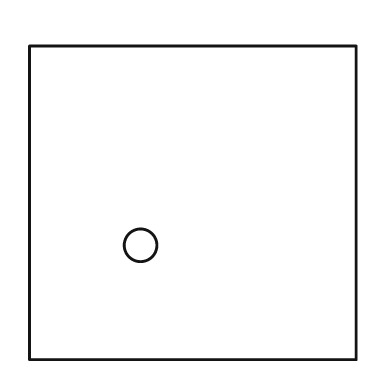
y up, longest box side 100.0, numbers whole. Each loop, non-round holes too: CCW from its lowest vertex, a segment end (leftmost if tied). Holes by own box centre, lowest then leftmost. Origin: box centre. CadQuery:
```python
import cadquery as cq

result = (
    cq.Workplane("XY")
    .moveTo(-50.0, -48.0)
    .lineTo(50.0, -48.0)
    .lineTo(50.0, 48.0)
    .lineTo(-50.0, 48.0)
    .close()
    .moveTo(-16.0, -13.0)
    .circle(5.0)
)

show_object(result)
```